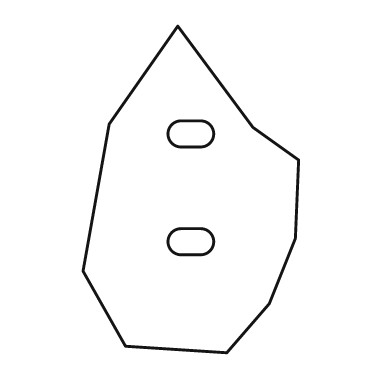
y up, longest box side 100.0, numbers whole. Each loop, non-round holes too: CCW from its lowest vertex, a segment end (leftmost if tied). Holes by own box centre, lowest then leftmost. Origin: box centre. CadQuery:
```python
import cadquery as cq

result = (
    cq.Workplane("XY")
    .moveTo(11.0, -50.0)
    .lineTo(24.0, -35.0)
    .lineTo(32.0, -15.0)
    .lineTo(33.0, 9.0)
    .lineTo(19.0, 19.0)
    .lineTo(-4.0, 50.0)
    .lineTo(-25.0, 20.0)
    .lineTo(-33.0, -25.0)
    .lineTo(-20.0, -48.0)
    .close()
    .moveTo(-3.0, -20.0)
    .lineTo(3.0, -20.0)
    .threePointArc((7.0, -16.0), (3.0, -12.0))
    .lineTo(-3.0, -12.0)
    .threePointArc((-7.0, -16.0), (-3.0, -20.0))
    .close()
    .moveTo(-3.0, 13.0)
    .lineTo(3.0, 13.0)
    .threePointArc((7.0, 17.0), (3.0, 21.0))
    .lineTo(-3.0, 21.0)
    .threePointArc((-7.0, 17.0), (-3.0, 13.0))
    .close()
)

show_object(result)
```